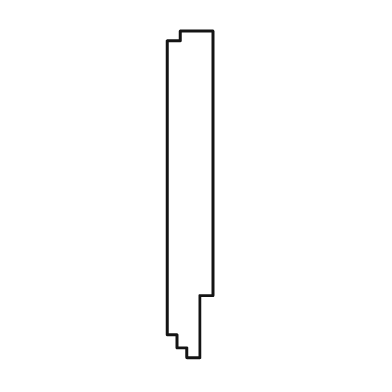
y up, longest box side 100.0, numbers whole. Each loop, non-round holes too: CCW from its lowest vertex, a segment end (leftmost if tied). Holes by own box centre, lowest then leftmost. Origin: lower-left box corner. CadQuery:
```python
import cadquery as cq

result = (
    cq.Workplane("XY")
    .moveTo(6.0, 0.0)
    .lineTo(10.0, 0.0)
    .lineTo(10.0, 19.0)
    .lineTo(14.0, 19.0)
    .lineTo(14.0, 100.0)
    .lineTo(4.0, 100.0)
    .lineTo(4.0, 97.0)
    .lineTo(0.0, 97.0)
    .lineTo(0.0, 7.0)
    .lineTo(3.0, 7.0)
    .lineTo(3.0, 3.0)
    .lineTo(6.0, 3.0)
    .close()
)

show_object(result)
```